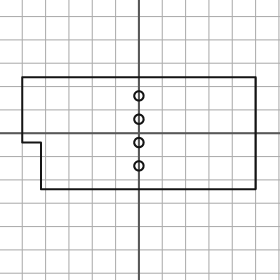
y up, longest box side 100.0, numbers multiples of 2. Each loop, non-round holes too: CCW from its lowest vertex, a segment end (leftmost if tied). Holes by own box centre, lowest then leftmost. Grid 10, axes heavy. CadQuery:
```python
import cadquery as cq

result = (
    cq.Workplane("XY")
    .moveTo(-42.0, -24.0)
    .lineTo(50.0, -24.0)
    .lineTo(50.0, 24.0)
    .lineTo(-50.0, 24.0)
    .lineTo(-50.0, -4.0)
    .lineTo(-42.0, -4.0)
    .close()
    .moveTo(0.0, -14.0)
    .circle(2.0)
    .moveTo(0.0, -4.0)
    .circle(2.0)
    .moveTo(0.0, 6.0)
    .circle(2.0)
    .moveTo(0.0, 16.0)
    .circle(2.0)
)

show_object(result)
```